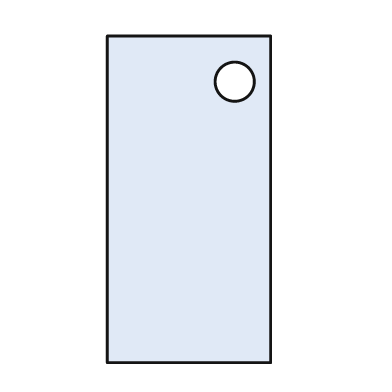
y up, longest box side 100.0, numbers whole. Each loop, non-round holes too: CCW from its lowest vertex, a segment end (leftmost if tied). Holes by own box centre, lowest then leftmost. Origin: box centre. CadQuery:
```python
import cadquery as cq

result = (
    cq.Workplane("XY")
    .moveTo(-25.0, -50.0)
    .lineTo(25.0, -50.0)
    .lineTo(25.0, 50.0)
    .lineTo(-25.0, 50.0)
    .close()
    .moveTo(14.0, 36.0)
    .circle(6.0)
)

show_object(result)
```